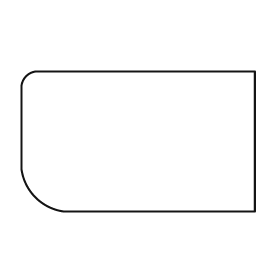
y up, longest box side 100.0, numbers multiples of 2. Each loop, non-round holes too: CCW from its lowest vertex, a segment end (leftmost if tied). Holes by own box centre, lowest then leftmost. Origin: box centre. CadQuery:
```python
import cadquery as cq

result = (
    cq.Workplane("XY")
    .moveTo(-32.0, -30.0)
    .lineTo(50.0, -30.0)
    .lineTo(50.0, 30.0)
    .lineTo(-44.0, 30.0)
    .threePointArc((-48.0, 28.0), (-50.0, 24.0))
    .lineTo(-50.0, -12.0)
    .threePointArc((-44.0, -24.0), (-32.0, -30.0))
    .close()
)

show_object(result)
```